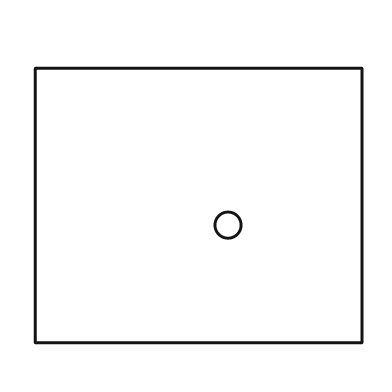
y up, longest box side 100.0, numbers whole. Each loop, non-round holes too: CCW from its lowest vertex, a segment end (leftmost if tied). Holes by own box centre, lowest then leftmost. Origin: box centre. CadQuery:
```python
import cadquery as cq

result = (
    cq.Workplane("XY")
    .moveTo(-50.0, -42.0)
    .lineTo(50.0, -42.0)
    .lineTo(50.0, 42.0)
    .lineTo(-50.0, 42.0)
    .close()
    .moveTo(9.0, -6.0)
    .circle(4.0)
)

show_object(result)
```